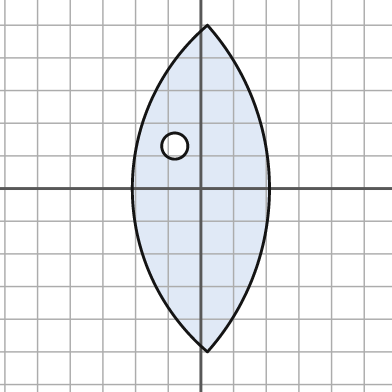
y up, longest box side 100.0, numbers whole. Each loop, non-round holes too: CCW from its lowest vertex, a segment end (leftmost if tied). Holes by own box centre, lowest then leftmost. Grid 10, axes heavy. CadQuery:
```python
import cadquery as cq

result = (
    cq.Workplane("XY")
    .moveTo(2.0, -50.0)
    .threePointArc((21.0, 0.0), (2.0, 50.0))
    .threePointArc((-21.0, 0.0), (2.0, -50.0))
    .close()
    .moveTo(-8.0, 13.0)
    .circle(4.0)
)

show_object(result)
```